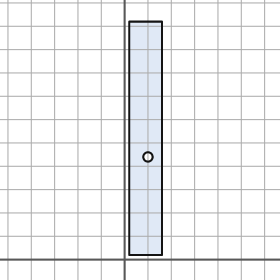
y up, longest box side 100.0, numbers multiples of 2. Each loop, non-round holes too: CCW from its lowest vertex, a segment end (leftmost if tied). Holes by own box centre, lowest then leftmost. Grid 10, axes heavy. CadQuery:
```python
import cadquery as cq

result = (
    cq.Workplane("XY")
    .moveTo(2.0, 2.0)
    .lineTo(16.0, 2.0)
    .lineTo(16.0, 102.0)
    .lineTo(2.0, 102.0)
    .close()
    .moveTo(10.0, 44.0)
    .circle(2.0)
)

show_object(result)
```